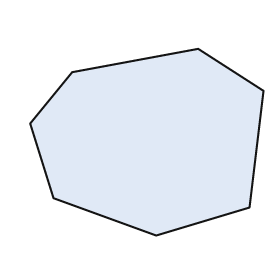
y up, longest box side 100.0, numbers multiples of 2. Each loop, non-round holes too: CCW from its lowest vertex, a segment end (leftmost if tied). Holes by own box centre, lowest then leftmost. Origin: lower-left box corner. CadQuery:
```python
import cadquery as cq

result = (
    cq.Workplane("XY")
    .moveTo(54.0, 0.0)
    .lineTo(94.0, 12.0)
    .lineTo(100.0, 62.0)
    .lineTo(72.0, 80.0)
    .lineTo(18.0, 70.0)
    .lineTo(0.0, 48.0)
    .lineTo(10.0, 16.0)
    .close()
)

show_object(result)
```